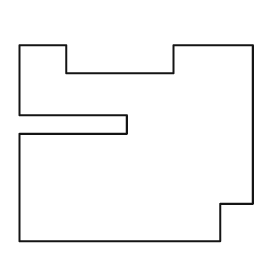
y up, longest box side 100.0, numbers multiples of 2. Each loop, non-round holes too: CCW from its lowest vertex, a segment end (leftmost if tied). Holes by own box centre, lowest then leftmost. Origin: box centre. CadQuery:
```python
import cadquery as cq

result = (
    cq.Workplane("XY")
    .moveTo(-50.0, -42.0)
    .lineTo(36.0, -42.0)
    .lineTo(36.0, -26.0)
    .lineTo(50.0, -26.0)
    .lineTo(50.0, 42.0)
    .lineTo(16.0, 42.0)
    .lineTo(16.0, 30.0)
    .lineTo(-30.0, 30.0)
    .lineTo(-30.0, 42.0)
    .lineTo(-50.0, 42.0)
    .lineTo(-50.0, 12.0)
    .lineTo(-4.0, 12.0)
    .lineTo(-4.0, 4.0)
    .lineTo(-50.0, 4.0)
    .close()
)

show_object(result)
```